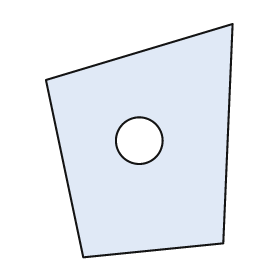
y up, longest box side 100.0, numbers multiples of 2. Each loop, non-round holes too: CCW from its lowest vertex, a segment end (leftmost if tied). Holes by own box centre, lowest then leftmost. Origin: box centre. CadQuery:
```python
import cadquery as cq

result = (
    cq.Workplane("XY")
    .moveTo(-24.0, -50.0)
    .lineTo(36.0, -44.0)
    .lineTo(40.0, 50.0)
    .lineTo(-40.0, 26.0)
    .close()
    .moveTo(0.0, 0.0)
    .circle(10.0)
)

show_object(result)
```